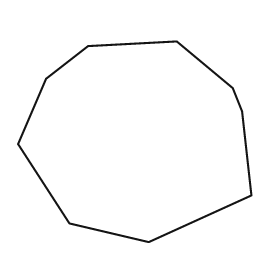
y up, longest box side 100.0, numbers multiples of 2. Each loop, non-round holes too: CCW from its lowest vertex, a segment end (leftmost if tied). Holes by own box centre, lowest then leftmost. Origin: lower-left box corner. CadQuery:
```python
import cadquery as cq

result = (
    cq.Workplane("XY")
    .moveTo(56.0, 0.0)
    .lineTo(100.0, 20.0)
    .lineTo(96.0, 56.0)
    .lineTo(92.0, 66.0)
    .lineTo(68.0, 86.0)
    .lineTo(30.0, 84.0)
    .lineTo(12.0, 70.0)
    .lineTo(0.0, 42.0)
    .lineTo(22.0, 8.0)
    .close()
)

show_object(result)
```